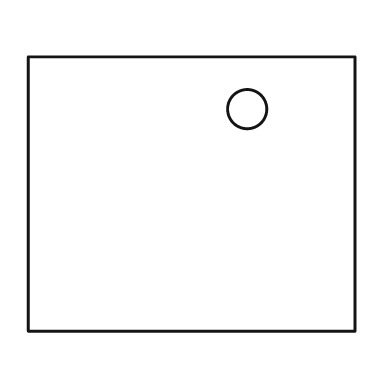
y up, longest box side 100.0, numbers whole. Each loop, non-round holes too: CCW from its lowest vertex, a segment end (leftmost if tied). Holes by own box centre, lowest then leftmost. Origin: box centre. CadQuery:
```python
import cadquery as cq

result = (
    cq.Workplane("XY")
    .moveTo(-50.0, -42.0)
    .lineTo(50.0, -42.0)
    .lineTo(50.0, 42.0)
    .lineTo(-50.0, 42.0)
    .close()
    .moveTo(17.0, 26.0)
    .circle(6.0)
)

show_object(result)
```